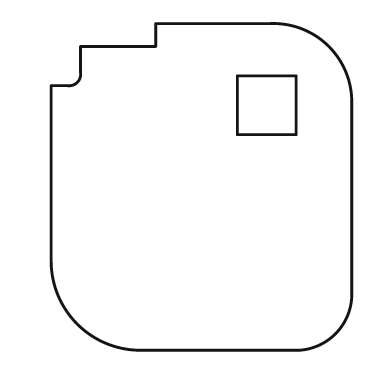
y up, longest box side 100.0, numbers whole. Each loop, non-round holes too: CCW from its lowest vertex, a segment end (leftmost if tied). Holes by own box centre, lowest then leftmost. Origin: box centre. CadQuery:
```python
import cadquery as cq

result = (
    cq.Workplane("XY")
    .moveTo(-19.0, -50.0)
    .lineTo(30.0, -50.0)
    .threePointArc((41.0, -45.0), (46.0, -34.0))
    .lineTo(46.0, 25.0)
    .threePointArc((39.0, 43.0), (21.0, 50.0))
    .lineTo(-14.0, 50.0)
    .lineTo(-14.0, 43.0)
    .lineTo(-37.0, 43.0)
    .lineTo(-37.0, 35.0)
    .threePointArc((-38.0, 32.0), (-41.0, 31.0))
    .lineTo(-46.0, 31.0)
    .lineTo(-46.0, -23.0)
    .threePointArc((-38.0, -42.0), (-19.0, -50.0))
    .close()
    .moveTo(11.0, 16.0)
    .lineTo(29.0, 16.0)
    .lineTo(29.0, 34.0)
    .lineTo(11.0, 34.0)
    .close()
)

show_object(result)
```